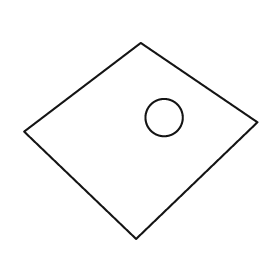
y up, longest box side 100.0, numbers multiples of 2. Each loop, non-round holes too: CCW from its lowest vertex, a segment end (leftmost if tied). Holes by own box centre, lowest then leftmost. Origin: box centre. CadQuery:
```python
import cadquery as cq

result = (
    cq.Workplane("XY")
    .moveTo(-2.0, -42.0)
    .lineTo(50.0, 8.0)
    .lineTo(0.0, 42.0)
    .lineTo(-50.0, 4.0)
    .close()
    .moveTo(10.0, 10.0)
    .circle(8.0)
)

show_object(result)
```